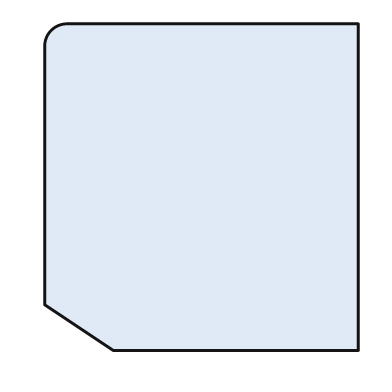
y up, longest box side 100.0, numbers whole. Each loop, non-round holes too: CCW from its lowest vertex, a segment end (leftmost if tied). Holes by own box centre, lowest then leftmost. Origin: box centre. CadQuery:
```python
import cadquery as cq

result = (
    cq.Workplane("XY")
    .moveTo(-27.0, -50.0)
    .lineTo(48.0, -50.0)
    .lineTo(48.0, 50.0)
    .lineTo(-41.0, 50.0)
    .threePointArc((-46.0, 48.0), (-48.0, 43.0))
    .lineTo(-48.0, -36.0)
    .close()
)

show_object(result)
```